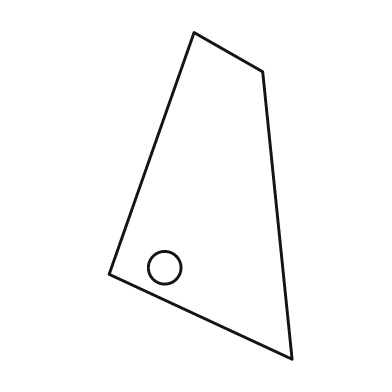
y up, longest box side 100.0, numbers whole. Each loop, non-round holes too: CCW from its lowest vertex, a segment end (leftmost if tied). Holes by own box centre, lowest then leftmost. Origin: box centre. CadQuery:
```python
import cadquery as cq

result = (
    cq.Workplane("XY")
    .moveTo(28.0, -50.0)
    .lineTo(19.0, 38.0)
    .lineTo(-2.0, 50.0)
    .lineTo(-28.0, -24.0)
    .close()
    .moveTo(-11.0, -22.0)
    .circle(5.0)
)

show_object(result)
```